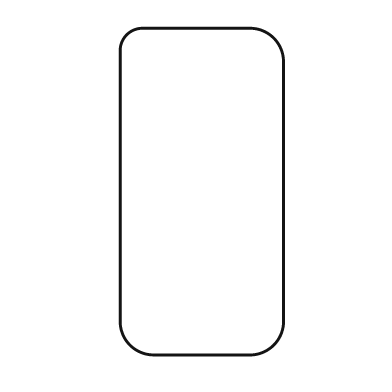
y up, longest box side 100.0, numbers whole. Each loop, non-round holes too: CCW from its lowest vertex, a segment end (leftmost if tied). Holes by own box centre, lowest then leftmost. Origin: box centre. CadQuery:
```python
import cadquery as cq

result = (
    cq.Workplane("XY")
    .moveTo(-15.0, -50.0)
    .lineTo(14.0, -50.0)
    .threePointArc((22.0, -47.0), (25.0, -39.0))
    .lineTo(25.0, 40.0)
    .threePointArc((22.0, 47.0), (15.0, 50.0))
    .lineTo(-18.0, 50.0)
    .threePointArc((-23.0, 48.0), (-25.0, 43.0))
    .lineTo(-25.0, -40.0)
    .threePointArc((-22.0, -47.0), (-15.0, -50.0))
    .close()
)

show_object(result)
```